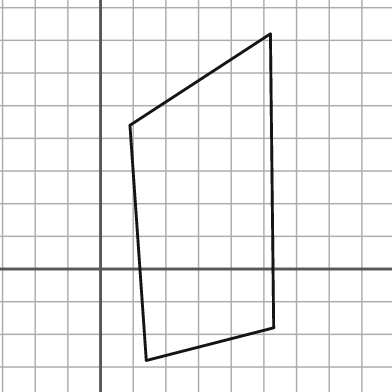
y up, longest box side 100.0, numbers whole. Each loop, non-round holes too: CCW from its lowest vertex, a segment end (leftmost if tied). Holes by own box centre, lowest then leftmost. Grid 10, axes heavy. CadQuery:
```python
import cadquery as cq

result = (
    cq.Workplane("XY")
    .moveTo(14.0, -28.0)
    .lineTo(53.0, -18.0)
    .lineTo(52.0, 72.0)
    .lineTo(9.0, 44.0)
    .close()
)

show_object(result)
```